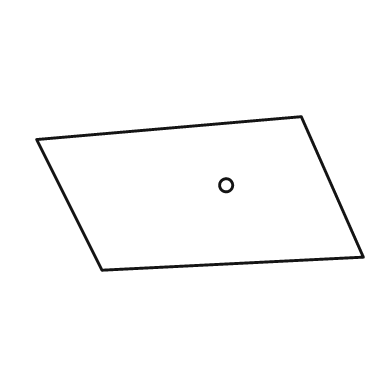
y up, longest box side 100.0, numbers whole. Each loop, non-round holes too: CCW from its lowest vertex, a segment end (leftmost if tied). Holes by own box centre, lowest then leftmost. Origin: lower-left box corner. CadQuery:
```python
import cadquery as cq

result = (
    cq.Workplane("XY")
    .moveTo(20.0, 0.0)
    .lineTo(100.0, 4.0)
    .lineTo(81.0, 47.0)
    .lineTo(0.0, 40.0)
    .close()
    .moveTo(58.0, 26.0)
    .circle(2.0)
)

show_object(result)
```